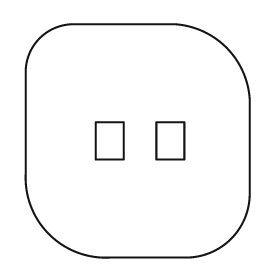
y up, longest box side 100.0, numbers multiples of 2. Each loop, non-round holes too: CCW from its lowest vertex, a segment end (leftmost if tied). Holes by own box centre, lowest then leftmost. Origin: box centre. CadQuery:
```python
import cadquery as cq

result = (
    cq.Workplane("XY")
    .moveTo(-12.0, -50.0)
    .lineTo(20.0, -50.0)
    .threePointArc((40.0, -42.0), (48.0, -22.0))
    .lineTo(48.0, 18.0)
    .threePointArc((38.0, 40.0), (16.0, 50.0))
    .lineTo(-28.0, 50.0)
    .threePointArc((-42.0, 44.0), (-48.0, 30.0))
    .lineTo(-48.0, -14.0)
    .threePointArc((-38.0, -40.0), (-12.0, -50.0))
    .close()
    .moveTo(-18.0, -8.0)
    .lineTo(-6.0, -8.0)
    .lineTo(-6.0, 8.0)
    .lineTo(-18.0, 8.0)
    .close()
    .moveTo(8.0, -8.0)
    .lineTo(20.0, -8.0)
    .lineTo(20.0, 8.0)
    .lineTo(8.0, 8.0)
    .close()
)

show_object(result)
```